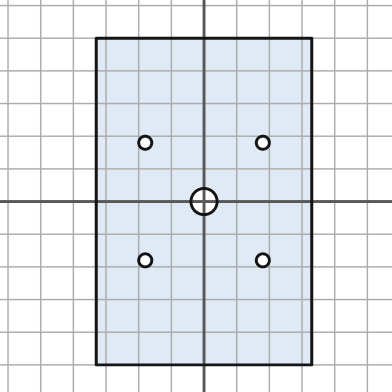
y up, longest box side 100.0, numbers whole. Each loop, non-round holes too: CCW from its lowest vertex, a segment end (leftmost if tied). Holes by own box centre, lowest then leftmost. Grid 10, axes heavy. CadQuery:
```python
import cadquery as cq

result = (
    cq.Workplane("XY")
    .moveTo(-33.0, -50.0)
    .lineTo(33.0, -50.0)
    .lineTo(33.0, 50.0)
    .lineTo(-33.0, 50.0)
    .close()
    .moveTo(-18.0, -18.0)
    .circle(2.0)
    .moveTo(18.0, -18.0)
    .circle(2.0)
    .moveTo(0.0, 0.0)
    .circle(4.0)
    .moveTo(-18.0, 18.0)
    .circle(2.0)
    .moveTo(18.0, 18.0)
    .circle(2.0)
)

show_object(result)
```